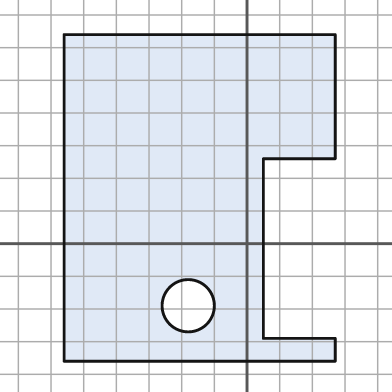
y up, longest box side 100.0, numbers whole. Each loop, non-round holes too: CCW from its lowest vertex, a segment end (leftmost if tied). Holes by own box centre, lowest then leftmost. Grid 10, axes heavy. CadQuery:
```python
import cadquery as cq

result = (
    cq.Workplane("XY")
    .moveTo(-56.0, -36.0)
    .lineTo(27.0, -36.0)
    .lineTo(27.0, -29.0)
    .lineTo(5.0, -29.0)
    .lineTo(5.0, 26.0)
    .lineTo(27.0, 26.0)
    .lineTo(27.0, 64.0)
    .lineTo(-56.0, 64.0)
    .close()
    .moveTo(-18.0, -19.0)
    .circle(8.0)
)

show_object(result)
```